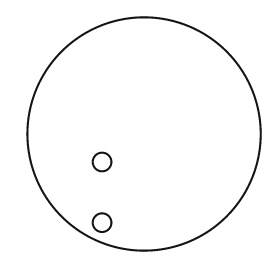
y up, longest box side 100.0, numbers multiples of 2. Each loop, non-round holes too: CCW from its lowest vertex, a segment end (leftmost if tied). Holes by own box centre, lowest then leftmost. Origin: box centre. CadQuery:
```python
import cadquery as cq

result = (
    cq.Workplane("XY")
    .moveTo(0.0, 0.0)
    .circle(50.0)
    .moveTo(-18.0, -38.0)
    .circle(4.0)
    .moveTo(-18.0, -12.0)
    .circle(4.0)
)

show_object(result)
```